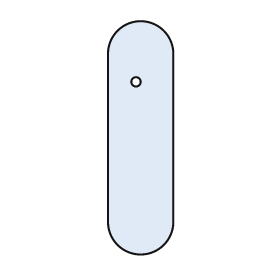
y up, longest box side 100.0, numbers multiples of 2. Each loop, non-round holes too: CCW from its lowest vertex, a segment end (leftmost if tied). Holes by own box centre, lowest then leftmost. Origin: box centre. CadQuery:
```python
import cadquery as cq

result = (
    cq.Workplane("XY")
    .moveTo(-14.0, -36.0)
    .threePointArc((0.0, -50.0), (14.0, -36.0))
    .lineTo(14.0, 36.0)
    .threePointArc((0.0, 50.0), (-14.0, 36.0))
    .close()
    .moveTo(-2.0, 24.0)
    .circle(2.0)
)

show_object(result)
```